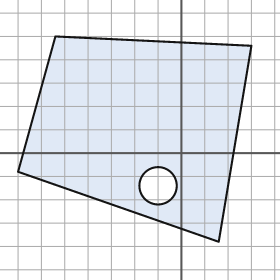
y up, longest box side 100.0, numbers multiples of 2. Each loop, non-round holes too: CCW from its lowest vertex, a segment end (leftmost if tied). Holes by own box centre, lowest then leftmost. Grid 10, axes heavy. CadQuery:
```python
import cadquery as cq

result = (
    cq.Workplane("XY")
    .moveTo(16.0, -38.0)
    .lineTo(30.0, 46.0)
    .lineTo(-54.0, 50.0)
    .lineTo(-70.0, -8.0)
    .close()
    .moveTo(-10.0, -14.0)
    .circle(8.0)
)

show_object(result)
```